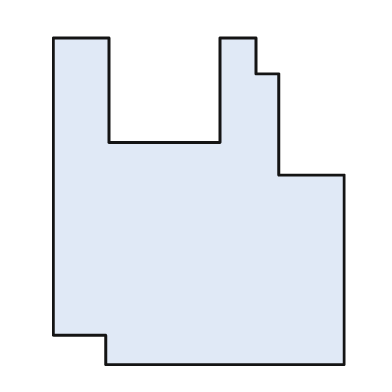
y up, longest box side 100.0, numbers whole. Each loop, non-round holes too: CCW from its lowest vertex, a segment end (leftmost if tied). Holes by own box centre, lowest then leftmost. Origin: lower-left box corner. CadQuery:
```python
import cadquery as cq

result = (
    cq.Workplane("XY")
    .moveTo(16.0, 0.0)
    .lineTo(89.0, 0.0)
    .lineTo(89.0, 58.0)
    .lineTo(69.0, 58.0)
    .lineTo(69.0, 89.0)
    .lineTo(62.0, 89.0)
    .lineTo(62.0, 100.0)
    .lineTo(51.0, 100.0)
    .lineTo(51.0, 68.0)
    .lineTo(17.0, 68.0)
    .lineTo(17.0, 100.0)
    .lineTo(0.0, 100.0)
    .lineTo(0.0, 9.0)
    .lineTo(16.0, 9.0)
    .close()
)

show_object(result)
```